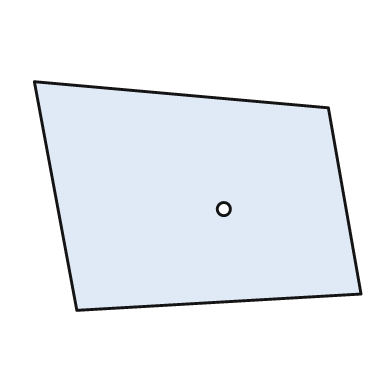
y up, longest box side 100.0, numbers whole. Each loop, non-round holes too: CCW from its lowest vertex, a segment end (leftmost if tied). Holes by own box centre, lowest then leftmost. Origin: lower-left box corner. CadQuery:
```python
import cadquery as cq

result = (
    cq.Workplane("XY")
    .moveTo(13.0, 0.0)
    .lineTo(100.0, 5.0)
    .lineTo(90.0, 62.0)
    .lineTo(0.0, 70.0)
    .close()
    .moveTo(58.0, 31.0)
    .circle(2.0)
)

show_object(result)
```